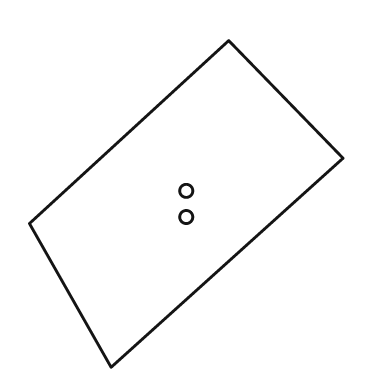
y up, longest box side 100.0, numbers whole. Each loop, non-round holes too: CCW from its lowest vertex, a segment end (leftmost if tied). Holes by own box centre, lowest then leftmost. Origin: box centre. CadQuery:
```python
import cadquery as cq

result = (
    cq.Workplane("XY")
    .moveTo(-23.0, -50.0)
    .lineTo(48.0, 14.0)
    .lineTo(13.0, 50.0)
    .lineTo(-48.0, -6.0)
    .close()
    .moveTo(0.0, -4.0)
    .circle(2.0)
    .moveTo(0.0, 4.0)
    .circle(2.0)
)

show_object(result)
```